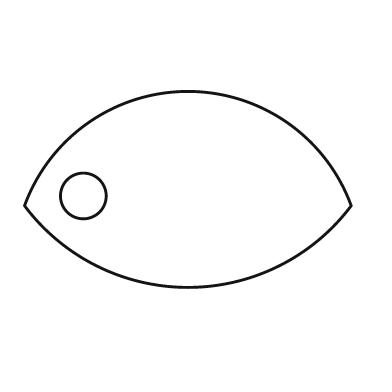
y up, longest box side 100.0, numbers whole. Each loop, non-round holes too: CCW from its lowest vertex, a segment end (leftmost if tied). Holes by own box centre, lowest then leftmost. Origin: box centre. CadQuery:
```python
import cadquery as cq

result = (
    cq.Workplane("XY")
    .moveTo(-50.0, -5.0)
    .threePointArc((0.0, -30.0), (50.0, -5.0))
    .threePointArc((0.0, 30.0), (-50.0, -5.0))
    .close()
    .moveTo(-32.0, -2.0)
    .circle(7.0)
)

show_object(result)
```